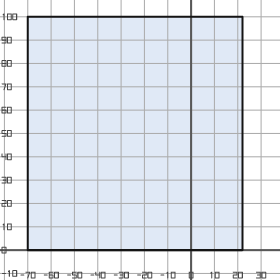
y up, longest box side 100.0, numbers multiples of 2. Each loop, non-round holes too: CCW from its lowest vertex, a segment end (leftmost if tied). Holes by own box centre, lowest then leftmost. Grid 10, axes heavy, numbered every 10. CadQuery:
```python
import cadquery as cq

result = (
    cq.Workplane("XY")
    .moveTo(-70.0, 0.0)
    .lineTo(22.0, 0.0)
    .lineTo(22.0, 100.0)
    .lineTo(-70.0, 100.0)
    .close()
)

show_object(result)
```